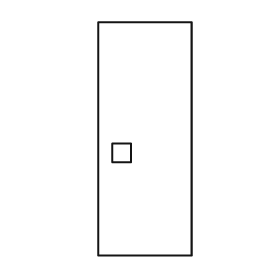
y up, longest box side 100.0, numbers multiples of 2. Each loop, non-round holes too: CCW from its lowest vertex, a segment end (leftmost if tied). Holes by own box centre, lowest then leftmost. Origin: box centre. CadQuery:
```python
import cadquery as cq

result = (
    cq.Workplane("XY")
    .moveTo(-20.0, -50.0)
    .lineTo(20.0, -50.0)
    .lineTo(20.0, 50.0)
    .lineTo(-20.0, 50.0)
    .close()
    .moveTo(-14.0, -10.0)
    .lineTo(-6.0, -10.0)
    .lineTo(-6.0, -2.0)
    .lineTo(-14.0, -2.0)
    .close()
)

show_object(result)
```